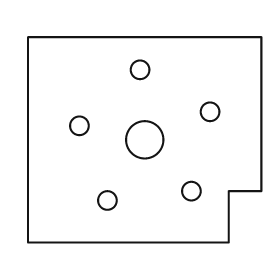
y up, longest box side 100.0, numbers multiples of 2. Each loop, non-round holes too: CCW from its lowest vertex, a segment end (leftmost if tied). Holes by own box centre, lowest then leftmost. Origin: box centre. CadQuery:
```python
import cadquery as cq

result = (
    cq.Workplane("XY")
    .moveTo(-50.0, -44.0)
    .lineTo(36.0, -44.0)
    .lineTo(36.0, -22.0)
    .lineTo(50.0, -22.0)
    .lineTo(50.0, 44.0)
    .lineTo(-50.0, 44.0)
    .close()
    .moveTo(-16.0, -26.0)
    .circle(4.0)
    .moveTo(20.0, -22.0)
    .circle(4.0)
    .moveTo(0.0, 0.0)
    .circle(8.0)
    .moveTo(-28.0, 6.0)
    .circle(4.0)
    .moveTo(28.0, 12.0)
    .circle(4.0)
    .moveTo(-2.0, 30.0)
    .circle(4.0)
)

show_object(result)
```